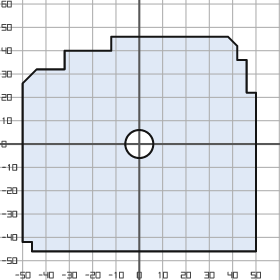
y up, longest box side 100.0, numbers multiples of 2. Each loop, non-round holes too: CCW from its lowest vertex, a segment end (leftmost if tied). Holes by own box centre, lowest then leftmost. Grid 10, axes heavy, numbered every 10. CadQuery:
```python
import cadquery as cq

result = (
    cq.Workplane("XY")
    .moveTo(-46.0, -46.0)
    .lineTo(50.0, -46.0)
    .lineTo(50.0, 22.0)
    .lineTo(46.0, 22.0)
    .lineTo(46.0, 36.0)
    .lineTo(42.0, 36.0)
    .lineTo(42.0, 42.0)
    .lineTo(38.0, 46.0)
    .lineTo(-12.0, 46.0)
    .lineTo(-12.0, 40.0)
    .lineTo(-32.0, 40.0)
    .lineTo(-32.0, 32.0)
    .lineTo(-44.0, 32.0)
    .lineTo(-50.0, 26.0)
    .lineTo(-50.0, -42.0)
    .lineTo(-46.0, -42.0)
    .close()
    .moveTo(0.0, 0.0)
    .circle(6.0)
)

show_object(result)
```